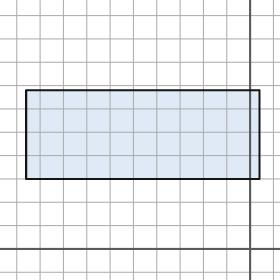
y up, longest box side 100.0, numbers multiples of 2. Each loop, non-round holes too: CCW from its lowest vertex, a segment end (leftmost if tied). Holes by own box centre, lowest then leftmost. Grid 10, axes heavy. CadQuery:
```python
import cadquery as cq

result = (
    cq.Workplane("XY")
    .moveTo(-96.0, 30.0)
    .lineTo(4.0, 30.0)
    .lineTo(4.0, 68.0)
    .lineTo(-96.0, 68.0)
    .close()
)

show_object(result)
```